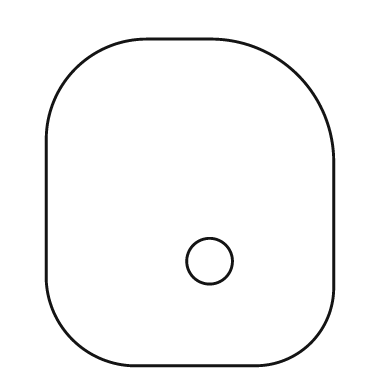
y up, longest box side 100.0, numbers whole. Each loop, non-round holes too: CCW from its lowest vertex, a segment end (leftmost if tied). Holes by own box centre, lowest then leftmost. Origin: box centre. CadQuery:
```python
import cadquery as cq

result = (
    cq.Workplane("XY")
    .moveTo(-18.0, -50.0)
    .lineTo(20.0, -50.0)
    .threePointArc((37.0, -43.0), (44.0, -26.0))
    .lineTo(44.0, 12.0)
    .threePointArc((33.0, 39.0), (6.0, 50.0))
    .lineTo(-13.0, 50.0)
    .threePointArc((-35.0, 41.0), (-44.0, 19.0))
    .lineTo(-44.0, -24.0)
    .threePointArc((-36.0, -42.0), (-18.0, -50.0))
    .close()
    .moveTo(6.0, -18.0)
    .circle(7.0)
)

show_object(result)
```